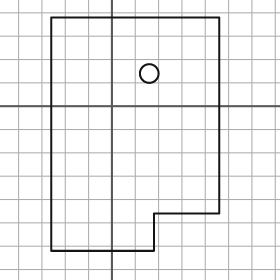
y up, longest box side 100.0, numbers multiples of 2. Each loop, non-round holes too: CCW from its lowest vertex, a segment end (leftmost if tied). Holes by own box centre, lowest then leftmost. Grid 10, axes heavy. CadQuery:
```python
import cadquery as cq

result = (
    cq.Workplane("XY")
    .moveTo(-26.0, -62.0)
    .lineTo(18.0, -62.0)
    .lineTo(18.0, -46.0)
    .lineTo(46.0, -46.0)
    .lineTo(46.0, 38.0)
    .lineTo(-26.0, 38.0)
    .close()
    .moveTo(16.0, 14.0)
    .circle(4.0)
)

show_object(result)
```